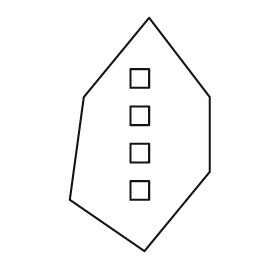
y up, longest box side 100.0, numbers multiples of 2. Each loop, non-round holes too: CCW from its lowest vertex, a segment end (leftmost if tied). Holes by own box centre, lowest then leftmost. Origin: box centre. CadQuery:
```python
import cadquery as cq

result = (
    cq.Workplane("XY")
    .moveTo(2.0, -50.0)
    .lineTo(30.0, -16.0)
    .lineTo(30.0, 16.0)
    .lineTo(4.0, 50.0)
    .lineTo(-24.0, 16.0)
    .lineTo(-30.0, -28.0)
    .close()
    .moveTo(-4.0, -28.0)
    .lineTo(4.0, -28.0)
    .lineTo(4.0, -20.0)
    .lineTo(-4.0, -20.0)
    .close()
    .moveTo(-4.0, -12.0)
    .lineTo(4.0, -12.0)
    .lineTo(4.0, -4.0)
    .lineTo(-4.0, -4.0)
    .close()
    .moveTo(-4.0, 4.0)
    .lineTo(4.0, 4.0)
    .lineTo(4.0, 12.0)
    .lineTo(-4.0, 12.0)
    .close()
    .moveTo(-4.0, 20.0)
    .lineTo(4.0, 20.0)
    .lineTo(4.0, 28.0)
    .lineTo(-4.0, 28.0)
    .close()
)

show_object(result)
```